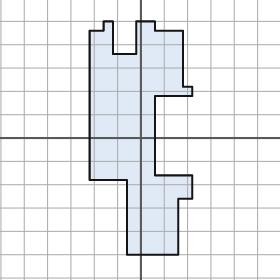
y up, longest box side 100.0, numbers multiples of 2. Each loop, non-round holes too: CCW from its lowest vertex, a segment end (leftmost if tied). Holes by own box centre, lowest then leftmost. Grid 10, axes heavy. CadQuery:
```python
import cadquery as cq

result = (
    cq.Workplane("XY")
    .moveTo(-6.0, -50.0)
    .lineTo(16.0, -50.0)
    .lineTo(16.0, -26.0)
    .lineTo(22.0, -26.0)
    .lineTo(22.0, -16.0)
    .lineTo(6.0, -16.0)
    .lineTo(6.0, 18.0)
    .lineTo(22.0, 18.0)
    .lineTo(22.0, 22.0)
    .lineTo(18.0, 22.0)
    .lineTo(18.0, 46.0)
    .lineTo(6.0, 46.0)
    .lineTo(6.0, 50.0)
    .lineTo(-2.0, 50.0)
    .lineTo(-2.0, 36.0)
    .lineTo(-12.0, 36.0)
    .lineTo(-12.0, 50.0)
    .lineTo(-16.0, 50.0)
    .lineTo(-16.0, 46.0)
    .lineTo(-22.0, 46.0)
    .lineTo(-22.0, -18.0)
    .lineTo(-6.0, -18.0)
    .close()
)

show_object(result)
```